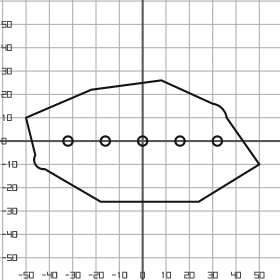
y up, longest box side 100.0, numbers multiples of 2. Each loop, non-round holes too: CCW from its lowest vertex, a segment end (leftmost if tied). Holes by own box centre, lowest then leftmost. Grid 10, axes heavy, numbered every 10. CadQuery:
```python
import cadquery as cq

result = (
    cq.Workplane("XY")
    .moveTo(-18.0, -26.0)
    .lineTo(24.0, -26.0)
    .lineTo(50.0, -10.0)
    .lineTo(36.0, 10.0)
    .threePointArc((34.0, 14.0), (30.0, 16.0))
    .lineTo(8.0, 26.0)
    .lineTo(-22.0, 22.0)
    .lineTo(-50.0, 10.0)
    .lineTo(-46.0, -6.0)
    .threePointArc((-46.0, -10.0), (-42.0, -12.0))
    .close()
    .moveTo(-32.0, 0.0)
    .circle(2.0)
    .moveTo(-16.0, 0.0)
    .circle(2.0)
    .moveTo(0.0, 0.0)
    .circle(2.0)
    .moveTo(16.0, 0.0)
    .circle(2.0)
    .moveTo(32.0, 0.0)
    .circle(2.0)
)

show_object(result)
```